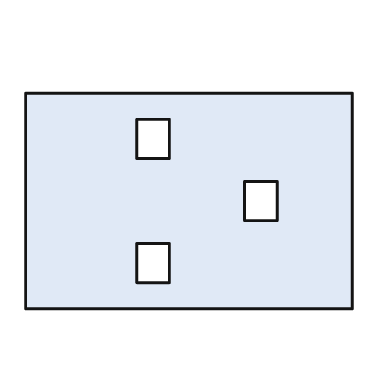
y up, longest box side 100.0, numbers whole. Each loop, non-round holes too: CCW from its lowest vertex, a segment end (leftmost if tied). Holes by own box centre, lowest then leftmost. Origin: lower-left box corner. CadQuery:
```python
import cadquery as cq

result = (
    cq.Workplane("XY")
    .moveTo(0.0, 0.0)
    .lineTo(100.0, 0.0)
    .lineTo(100.0, 66.0)
    .lineTo(0.0, 66.0)
    .close()
    .moveTo(34.0, 8.0)
    .lineTo(44.0, 8.0)
    .lineTo(44.0, 20.0)
    .lineTo(34.0, 20.0)
    .close()
    .moveTo(67.0, 27.0)
    .lineTo(77.0, 27.0)
    .lineTo(77.0, 39.0)
    .lineTo(67.0, 39.0)
    .close()
    .moveTo(34.0, 46.0)
    .lineTo(44.0, 46.0)
    .lineTo(44.0, 58.0)
    .lineTo(34.0, 58.0)
    .close()
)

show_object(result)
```